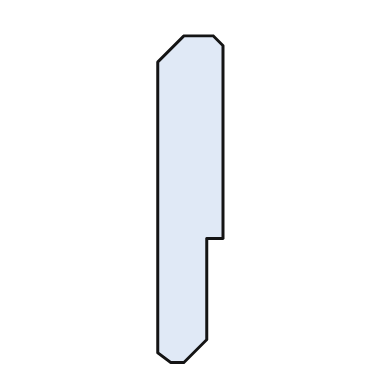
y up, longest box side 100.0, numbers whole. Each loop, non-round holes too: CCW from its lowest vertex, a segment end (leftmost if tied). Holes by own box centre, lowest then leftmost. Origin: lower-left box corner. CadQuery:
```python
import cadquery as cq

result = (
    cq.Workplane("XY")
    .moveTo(4.0, 0.0)
    .lineTo(8.0, 0.0)
    .lineTo(15.0, 7.0)
    .lineTo(15.0, 38.0)
    .lineTo(20.0, 38.0)
    .lineTo(20.0, 97.0)
    .lineTo(17.0, 100.0)
    .lineTo(8.0, 100.0)
    .lineTo(0.0, 92.0)
    .lineTo(0.0, 3.0)
    .close()
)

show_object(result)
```